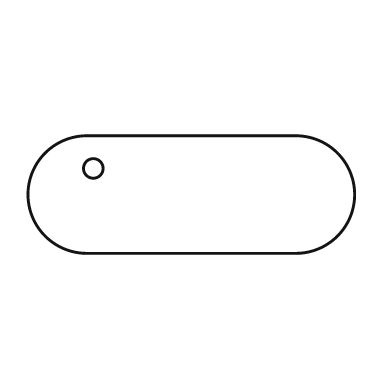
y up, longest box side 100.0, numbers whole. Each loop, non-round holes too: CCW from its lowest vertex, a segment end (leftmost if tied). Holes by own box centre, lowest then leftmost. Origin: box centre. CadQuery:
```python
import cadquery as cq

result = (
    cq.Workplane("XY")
    .moveTo(-32.0, -18.0)
    .lineTo(32.0, -18.0)
    .threePointArc((50.0, 0.0), (32.0, 18.0))
    .lineTo(-32.0, 18.0)
    .threePointArc((-50.0, 0.0), (-32.0, -18.0))
    .close()
    .moveTo(-30.0, 8.0)
    .circle(3.0)
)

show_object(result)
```